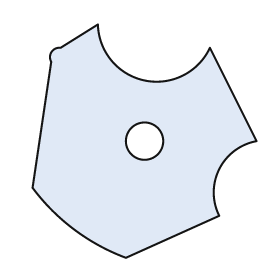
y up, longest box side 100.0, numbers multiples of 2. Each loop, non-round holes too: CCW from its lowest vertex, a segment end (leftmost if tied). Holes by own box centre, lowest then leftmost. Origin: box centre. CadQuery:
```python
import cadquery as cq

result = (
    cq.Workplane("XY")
    .moveTo(-8.0, -50.0)
    .lineTo(32.0, -32.0)
    .threePointArc((32.0, -12.0), (48.0, 0.0))
    .lineTo(28.0, 40.0)
    .threePointArc((0.0, 26.0), (-20.0, 50.0))
    .lineTo(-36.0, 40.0)
    .threePointArc((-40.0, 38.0), (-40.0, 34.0))
    .lineTo(-48.0, -20.0)
    .threePointArc((-30.0, -38.0), (-8.0, -50.0))
    .close()
    .moveTo(0.0, 0.0)
    .circle(8.0)
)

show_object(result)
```